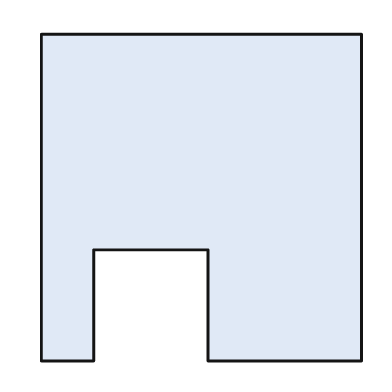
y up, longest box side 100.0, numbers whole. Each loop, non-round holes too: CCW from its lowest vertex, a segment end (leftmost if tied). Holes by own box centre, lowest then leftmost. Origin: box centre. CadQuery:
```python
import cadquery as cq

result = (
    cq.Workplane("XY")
    .moveTo(-49.0, -50.0)
    .lineTo(-33.0, -50.0)
    .lineTo(-33.0, -16.0)
    .lineTo(2.0, -16.0)
    .lineTo(2.0, -50.0)
    .lineTo(49.0, -50.0)
    .lineTo(49.0, 50.0)
    .lineTo(-49.0, 50.0)
    .close()
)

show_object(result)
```